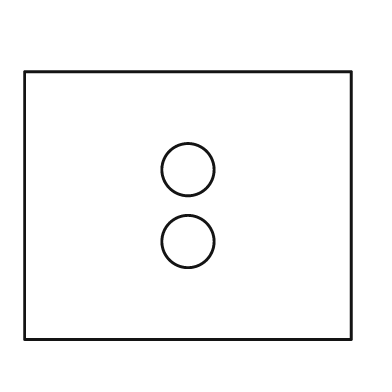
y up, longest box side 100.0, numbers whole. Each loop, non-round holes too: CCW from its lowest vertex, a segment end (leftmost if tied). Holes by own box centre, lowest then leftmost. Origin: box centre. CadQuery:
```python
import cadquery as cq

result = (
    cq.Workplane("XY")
    .moveTo(-50.0, -41.0)
    .lineTo(50.0, -41.0)
    .lineTo(50.0, 41.0)
    .lineTo(-50.0, 41.0)
    .close()
    .moveTo(0.0, -11.0)
    .circle(8.0)
    .moveTo(0.0, 11.0)
    .circle(8.0)
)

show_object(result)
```